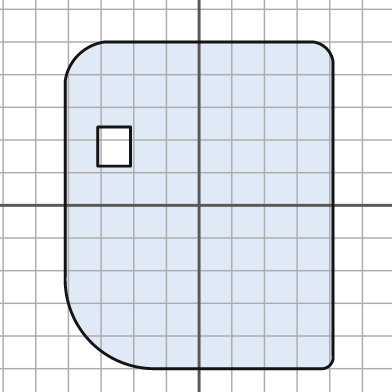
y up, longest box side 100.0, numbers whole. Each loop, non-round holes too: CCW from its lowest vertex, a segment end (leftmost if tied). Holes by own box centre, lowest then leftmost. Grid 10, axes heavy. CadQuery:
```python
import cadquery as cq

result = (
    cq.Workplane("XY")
    .moveTo(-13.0, -50.0)
    .lineTo(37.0, -50.0)
    .threePointArc((40.0, -49.0), (41.0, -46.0))
    .lineTo(41.0, 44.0)
    .threePointArc((39.0, 48.0), (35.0, 50.0))
    .lineTo(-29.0, 50.0)
    .threePointArc((-37.0, 46.0), (-41.0, 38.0))
    .lineTo(-41.0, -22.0)
    .threePointArc((-33.0, -42.0), (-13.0, -50.0))
    .close()
    .moveTo(-31.0, 12.0)
    .lineTo(-21.0, 12.0)
    .lineTo(-21.0, 24.0)
    .lineTo(-31.0, 24.0)
    .close()
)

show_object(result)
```